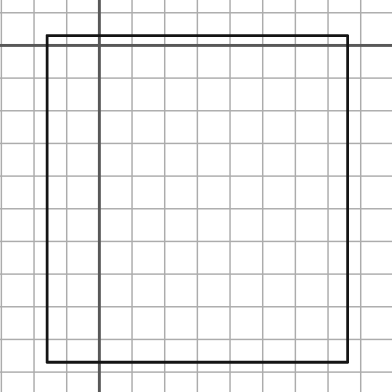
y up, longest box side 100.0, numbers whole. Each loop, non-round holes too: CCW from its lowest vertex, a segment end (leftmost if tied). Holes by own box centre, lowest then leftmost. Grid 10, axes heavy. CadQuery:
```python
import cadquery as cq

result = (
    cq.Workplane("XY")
    .moveTo(-16.0, -97.0)
    .lineTo(76.0, -97.0)
    .lineTo(76.0, 3.0)
    .lineTo(-16.0, 3.0)
    .close()
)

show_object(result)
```